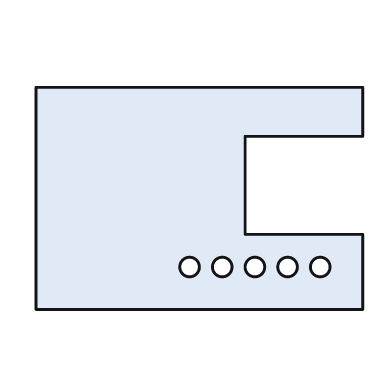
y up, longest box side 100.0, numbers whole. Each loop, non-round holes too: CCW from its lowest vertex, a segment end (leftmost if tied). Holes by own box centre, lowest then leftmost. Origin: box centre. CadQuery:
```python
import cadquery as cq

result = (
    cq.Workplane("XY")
    .moveTo(-50.0, -34.0)
    .lineTo(50.0, -34.0)
    .lineTo(50.0, -11.0)
    .lineTo(14.0, -11.0)
    .lineTo(14.0, 19.0)
    .lineTo(50.0, 19.0)
    .lineTo(50.0, 34.0)
    .lineTo(-50.0, 34.0)
    .close()
    .moveTo(-3.0, -21.0)
    .circle(3.0)
    .moveTo(7.0, -21.0)
    .circle(3.0)
    .moveTo(17.0, -21.0)
    .circle(3.0)
    .moveTo(27.0, -21.0)
    .circle(3.0)
    .moveTo(37.0, -21.0)
    .circle(3.0)
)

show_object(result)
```